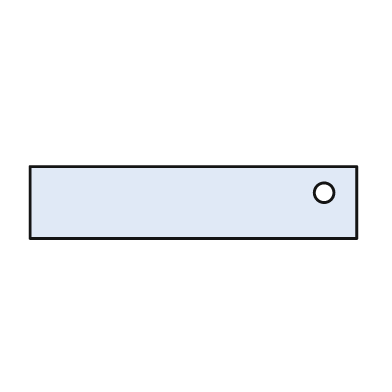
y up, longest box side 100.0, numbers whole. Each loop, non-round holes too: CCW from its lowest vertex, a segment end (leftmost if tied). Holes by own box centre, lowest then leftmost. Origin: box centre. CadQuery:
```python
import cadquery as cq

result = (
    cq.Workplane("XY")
    .moveTo(-50.0, -11.0)
    .lineTo(50.0, -11.0)
    .lineTo(50.0, 11.0)
    .lineTo(-50.0, 11.0)
    .close()
    .moveTo(40.0, 3.0)
    .circle(3.0)
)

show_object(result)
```